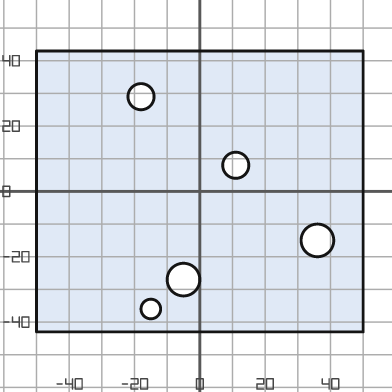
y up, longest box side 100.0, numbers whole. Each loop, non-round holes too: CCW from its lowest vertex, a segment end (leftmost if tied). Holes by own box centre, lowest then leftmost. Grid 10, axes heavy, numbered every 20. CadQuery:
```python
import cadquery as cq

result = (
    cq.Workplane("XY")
    .moveTo(-50.0, -43.0)
    .lineTo(50.0, -43.0)
    .lineTo(50.0, 43.0)
    .lineTo(-50.0, 43.0)
    .close()
    .moveTo(-15.0, -36.0)
    .circle(3.0)
    .moveTo(-5.0, -27.0)
    .circle(5.0)
    .moveTo(36.0, -15.0)
    .circle(5.0)
    .moveTo(11.0, 8.0)
    .circle(4.0)
    .moveTo(-18.0, 29.0)
    .circle(4.0)
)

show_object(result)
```